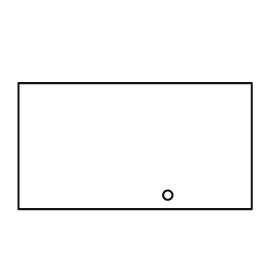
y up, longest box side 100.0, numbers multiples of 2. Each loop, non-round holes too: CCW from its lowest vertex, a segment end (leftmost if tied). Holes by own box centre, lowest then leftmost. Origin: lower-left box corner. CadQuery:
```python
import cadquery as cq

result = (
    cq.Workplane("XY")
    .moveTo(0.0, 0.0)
    .lineTo(100.0, 0.0)
    .lineTo(100.0, 54.0)
    .lineTo(0.0, 54.0)
    .close()
    .moveTo(64.0, 6.0)
    .circle(2.0)
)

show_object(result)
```